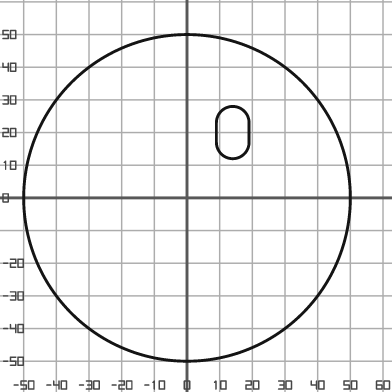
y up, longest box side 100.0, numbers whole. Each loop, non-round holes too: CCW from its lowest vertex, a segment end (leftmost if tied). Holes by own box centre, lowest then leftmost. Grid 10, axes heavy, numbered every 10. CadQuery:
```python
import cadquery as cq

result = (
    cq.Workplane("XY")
    .moveTo(0.0, 0.0)
    .circle(50.0)
    .moveTo(9.0, 17.0)
    .threePointArc((14.0, 12.0), (19.0, 17.0))
    .lineTo(19.0, 23.0)
    .threePointArc((14.0, 28.0), (9.0, 23.0))
    .close()
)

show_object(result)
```